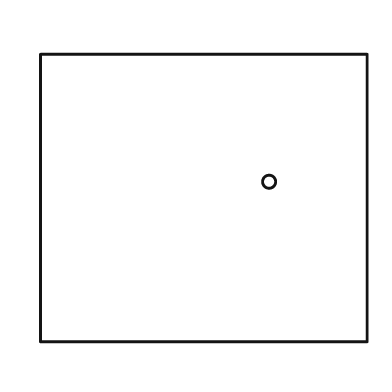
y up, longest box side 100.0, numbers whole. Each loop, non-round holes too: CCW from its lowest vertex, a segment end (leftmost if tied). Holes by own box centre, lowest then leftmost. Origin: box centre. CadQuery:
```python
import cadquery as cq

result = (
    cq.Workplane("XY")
    .moveTo(-50.0, -44.0)
    .lineTo(50.0, -44.0)
    .lineTo(50.0, 44.0)
    .lineTo(-50.0, 44.0)
    .close()
    .moveTo(20.0, 5.0)
    .circle(2.0)
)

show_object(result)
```